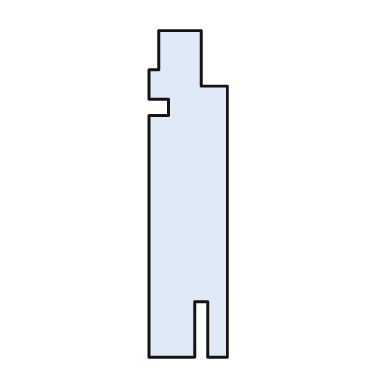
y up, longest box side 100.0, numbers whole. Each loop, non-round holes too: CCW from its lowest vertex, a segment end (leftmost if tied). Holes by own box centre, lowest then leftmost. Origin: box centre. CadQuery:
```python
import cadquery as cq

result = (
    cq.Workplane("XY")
    .moveTo(-12.0, -50.0)
    .lineTo(2.0, -50.0)
    .lineTo(2.0, -33.0)
    .lineTo(6.0, -33.0)
    .lineTo(6.0, -50.0)
    .lineTo(12.0, -50.0)
    .lineTo(12.0, 33.0)
    .lineTo(4.0, 33.0)
    .lineTo(4.0, 50.0)
    .lineTo(-9.0, 50.0)
    .lineTo(-9.0, 38.0)
    .lineTo(-12.0, 38.0)
    .lineTo(-12.0, 29.0)
    .lineTo(-6.0, 29.0)
    .lineTo(-6.0, 24.0)
    .lineTo(-12.0, 24.0)
    .close()
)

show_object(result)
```